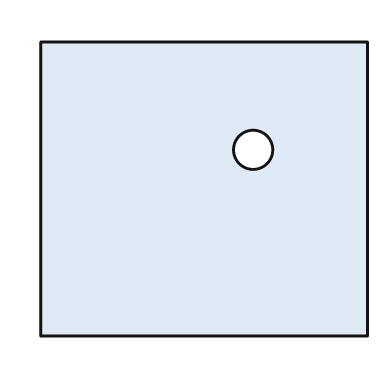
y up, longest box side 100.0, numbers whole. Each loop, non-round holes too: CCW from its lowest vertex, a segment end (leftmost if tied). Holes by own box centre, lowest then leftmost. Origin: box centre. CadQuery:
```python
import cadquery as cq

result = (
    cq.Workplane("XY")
    .moveTo(-50.0, -45.0)
    .lineTo(50.0, -45.0)
    .lineTo(50.0, 45.0)
    .lineTo(-50.0, 45.0)
    .close()
    .moveTo(15.0, 12.0)
    .circle(6.0)
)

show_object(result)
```